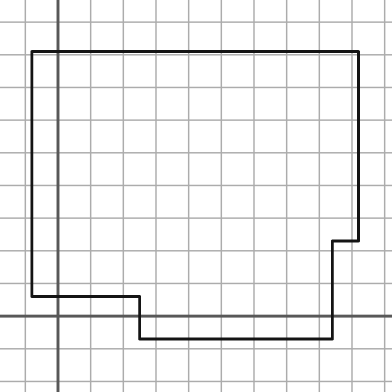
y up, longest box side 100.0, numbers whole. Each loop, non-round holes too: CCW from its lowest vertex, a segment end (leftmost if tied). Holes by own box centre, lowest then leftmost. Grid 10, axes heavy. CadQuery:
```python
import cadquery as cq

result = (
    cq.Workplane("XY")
    .moveTo(25.0, -7.0)
    .lineTo(84.0, -7.0)
    .lineTo(84.0, 23.0)
    .lineTo(92.0, 23.0)
    .lineTo(92.0, 81.0)
    .lineTo(-8.0, 81.0)
    .lineTo(-8.0, 6.0)
    .lineTo(25.0, 6.0)
    .close()
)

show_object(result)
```